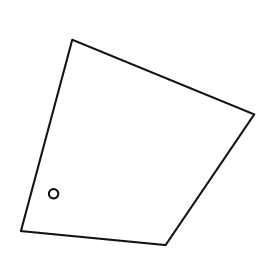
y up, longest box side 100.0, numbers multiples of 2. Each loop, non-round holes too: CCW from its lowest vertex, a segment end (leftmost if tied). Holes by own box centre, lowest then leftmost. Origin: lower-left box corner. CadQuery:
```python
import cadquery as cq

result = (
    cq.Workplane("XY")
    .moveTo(62.0, 0.0)
    .lineTo(100.0, 56.0)
    .lineTo(22.0, 88.0)
    .lineTo(0.0, 6.0)
    .close()
    .moveTo(14.0, 22.0)
    .circle(2.0)
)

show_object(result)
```